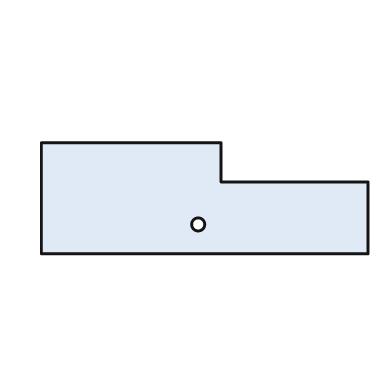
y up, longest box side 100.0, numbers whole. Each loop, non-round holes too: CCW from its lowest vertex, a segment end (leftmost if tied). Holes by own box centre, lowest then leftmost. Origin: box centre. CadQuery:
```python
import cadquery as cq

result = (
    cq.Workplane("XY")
    .moveTo(-50.0, -17.0)
    .lineTo(50.0, -17.0)
    .lineTo(50.0, 5.0)
    .lineTo(5.0, 5.0)
    .lineTo(5.0, 17.0)
    .lineTo(-50.0, 17.0)
    .close()
    .moveTo(-2.0, -8.0)
    .circle(2.0)
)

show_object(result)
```